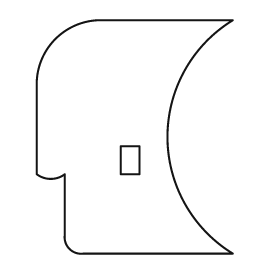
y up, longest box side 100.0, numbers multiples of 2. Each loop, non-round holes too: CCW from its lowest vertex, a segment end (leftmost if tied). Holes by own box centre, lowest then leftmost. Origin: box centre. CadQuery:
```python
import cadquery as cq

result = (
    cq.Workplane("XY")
    .moveTo(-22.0, -50.0)
    .lineTo(42.0, -50.0)
    .threePointArc((14.0, 0.0), (42.0, 50.0))
    .lineTo(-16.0, 50.0)
    .threePointArc((-34.0, 42.0), (-42.0, 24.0))
    .lineTo(-42.0, -16.0)
    .threePointArc((-36.0, -18.0), (-30.0, -16.0))
    .lineTo(-30.0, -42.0)
    .threePointArc((-28.0, -48.0), (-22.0, -50.0))
    .close()
    .moveTo(-6.0, -16.0)
    .lineTo(2.0, -16.0)
    .lineTo(2.0, -4.0)
    .lineTo(-6.0, -4.0)
    .close()
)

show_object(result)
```